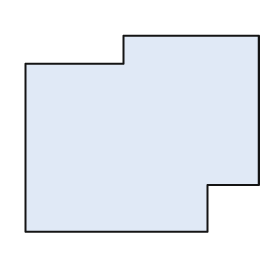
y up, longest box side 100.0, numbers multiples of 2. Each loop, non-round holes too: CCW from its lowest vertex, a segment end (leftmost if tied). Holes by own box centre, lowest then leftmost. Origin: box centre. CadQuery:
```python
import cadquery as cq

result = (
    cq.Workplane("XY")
    .moveTo(-50.0, -42.0)
    .lineTo(28.0, -42.0)
    .lineTo(28.0, -22.0)
    .lineTo(50.0, -22.0)
    .lineTo(50.0, 42.0)
    .lineTo(-8.0, 42.0)
    .lineTo(-8.0, 30.0)
    .lineTo(-50.0, 30.0)
    .close()
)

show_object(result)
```